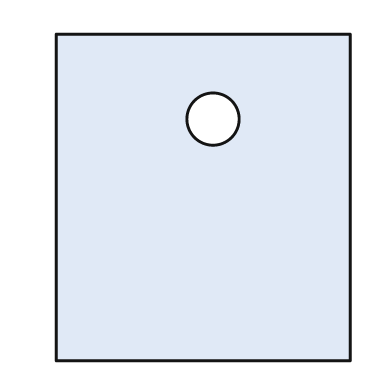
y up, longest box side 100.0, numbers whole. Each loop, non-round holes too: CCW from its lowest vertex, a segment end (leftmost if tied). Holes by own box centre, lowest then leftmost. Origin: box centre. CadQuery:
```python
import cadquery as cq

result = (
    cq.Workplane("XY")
    .moveTo(-45.0, -50.0)
    .lineTo(45.0, -50.0)
    .lineTo(45.0, 50.0)
    .lineTo(-45.0, 50.0)
    .close()
    .moveTo(3.0, 24.0)
    .circle(8.0)
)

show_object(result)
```